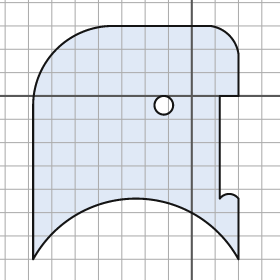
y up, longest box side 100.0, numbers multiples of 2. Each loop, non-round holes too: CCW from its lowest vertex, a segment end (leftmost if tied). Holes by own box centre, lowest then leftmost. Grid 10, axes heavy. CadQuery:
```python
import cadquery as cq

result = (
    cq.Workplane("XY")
    .moveTo(-68.0, -70.0)
    .threePointArc((-24.0, -44.0), (20.0, -70.0))
    .lineTo(20.0, -44.0)
    .threePointArc((16.0, -42.0), (12.0, -44.0))
    .lineTo(12.0, 0.0)
    .lineTo(20.0, 0.0)
    .lineTo(20.0, 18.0)
    .threePointArc((16.0, 26.0), (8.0, 30.0))
    .lineTo(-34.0, 30.0)
    .threePointArc((-58.0, 20.0), (-68.0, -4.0))
    .close()
    .moveTo(-12.0, -4.0)
    .circle(4.0)
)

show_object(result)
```